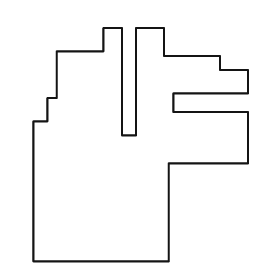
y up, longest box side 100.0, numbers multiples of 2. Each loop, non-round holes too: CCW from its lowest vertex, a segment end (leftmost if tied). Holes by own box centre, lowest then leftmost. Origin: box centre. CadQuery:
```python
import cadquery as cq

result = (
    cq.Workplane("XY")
    .moveTo(-46.0, -50.0)
    .lineTo(12.0, -50.0)
    .lineTo(12.0, -8.0)
    .lineTo(46.0, -8.0)
    .lineTo(46.0, 14.0)
    .lineTo(14.0, 14.0)
    .lineTo(14.0, 22.0)
    .lineTo(46.0, 22.0)
    .lineTo(46.0, 32.0)
    .lineTo(34.0, 32.0)
    .lineTo(34.0, 38.0)
    .lineTo(10.0, 38.0)
    .lineTo(10.0, 50.0)
    .lineTo(-2.0, 50.0)
    .lineTo(-2.0, 4.0)
    .lineTo(-8.0, 4.0)
    .lineTo(-8.0, 50.0)
    .lineTo(-16.0, 50.0)
    .lineTo(-16.0, 40.0)
    .lineTo(-36.0, 40.0)
    .lineTo(-36.0, 20.0)
    .lineTo(-40.0, 20.0)
    .lineTo(-40.0, 10.0)
    .lineTo(-46.0, 10.0)
    .close()
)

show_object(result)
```